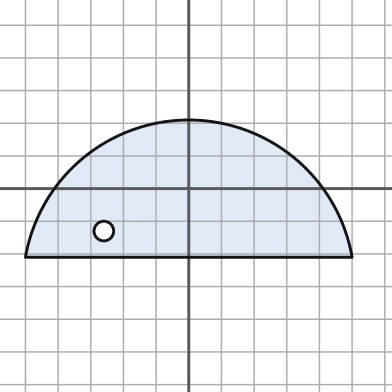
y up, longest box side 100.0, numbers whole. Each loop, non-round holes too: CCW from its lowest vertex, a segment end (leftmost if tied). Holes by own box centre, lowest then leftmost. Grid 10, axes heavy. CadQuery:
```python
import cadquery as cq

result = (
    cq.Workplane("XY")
    .moveTo(-50.0, -21.0)
    .lineTo(50.0, -21.0)
    .threePointArc((0.0, 21.0), (-50.0, -21.0))
    .close()
    .moveTo(-26.0, -13.0)
    .circle(3.0)
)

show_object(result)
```